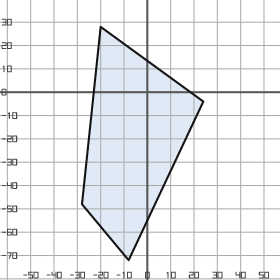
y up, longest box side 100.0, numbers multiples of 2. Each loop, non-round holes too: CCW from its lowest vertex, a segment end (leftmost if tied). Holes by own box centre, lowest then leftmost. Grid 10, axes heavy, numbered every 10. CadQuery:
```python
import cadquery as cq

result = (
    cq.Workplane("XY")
    .moveTo(-8.0, -72.0)
    .lineTo(24.0, -4.0)
    .lineTo(-20.0, 28.0)
    .lineTo(-28.0, -48.0)
    .close()
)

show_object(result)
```